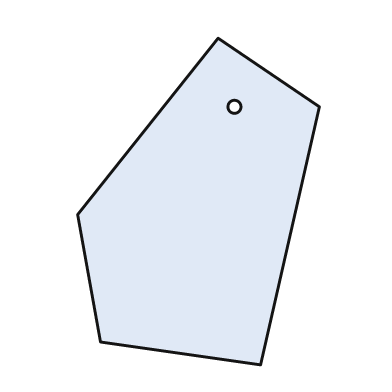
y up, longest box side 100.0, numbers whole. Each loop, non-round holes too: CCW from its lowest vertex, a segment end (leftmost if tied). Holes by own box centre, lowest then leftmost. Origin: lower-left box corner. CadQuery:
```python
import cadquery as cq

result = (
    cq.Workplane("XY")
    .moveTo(56.0, 0.0)
    .lineTo(74.0, 79.0)
    .lineTo(43.0, 100.0)
    .lineTo(0.0, 46.0)
    .lineTo(7.0, 7.0)
    .close()
    .moveTo(48.0, 79.0)
    .circle(2.0)
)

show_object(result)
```